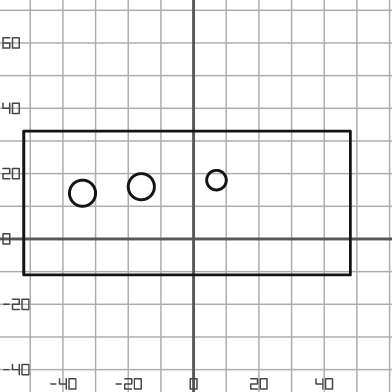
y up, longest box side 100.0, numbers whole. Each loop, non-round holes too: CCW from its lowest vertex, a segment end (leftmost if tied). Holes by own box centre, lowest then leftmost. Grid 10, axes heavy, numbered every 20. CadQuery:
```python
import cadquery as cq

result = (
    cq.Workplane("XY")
    .moveTo(-52.0, -11.0)
    .lineTo(48.0, -11.0)
    .lineTo(48.0, 33.0)
    .lineTo(-52.0, 33.0)
    .close()
    .moveTo(-34.0, 14.0)
    .circle(4.0)
    .moveTo(-16.0, 16.0)
    .circle(4.0)
    .moveTo(7.0, 18.0)
    .circle(3.0)
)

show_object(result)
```